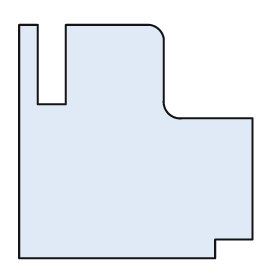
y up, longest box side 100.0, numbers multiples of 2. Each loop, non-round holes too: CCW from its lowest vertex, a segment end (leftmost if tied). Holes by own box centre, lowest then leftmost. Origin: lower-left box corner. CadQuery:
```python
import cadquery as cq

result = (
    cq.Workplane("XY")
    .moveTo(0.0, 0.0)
    .lineTo(84.0, 0.0)
    .lineTo(84.0, 8.0)
    .lineTo(100.0, 8.0)
    .lineTo(100.0, 60.0)
    .lineTo(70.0, 60.0)
    .threePointArc((64.0, 62.0), (62.0, 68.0))
    .lineTo(62.0, 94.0)
    .threePointArc((60.0, 98.0), (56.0, 100.0))
    .lineTo(20.0, 100.0)
    .lineTo(20.0, 66.0)
    .lineTo(8.0, 66.0)
    .lineTo(8.0, 100.0)
    .lineTo(0.0, 100.0)
    .close()
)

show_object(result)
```